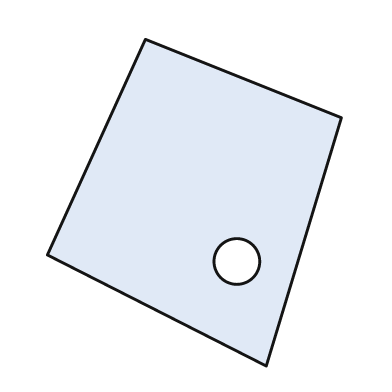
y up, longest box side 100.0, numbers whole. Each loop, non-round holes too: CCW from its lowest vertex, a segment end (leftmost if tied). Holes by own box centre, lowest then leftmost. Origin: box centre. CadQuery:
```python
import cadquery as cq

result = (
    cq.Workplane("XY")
    .moveTo(22.0, -50.0)
    .lineTo(45.0, 26.0)
    .lineTo(-15.0, 50.0)
    .lineTo(-45.0, -16.0)
    .close()
    .moveTo(13.0, -18.0)
    .circle(7.0)
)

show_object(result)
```